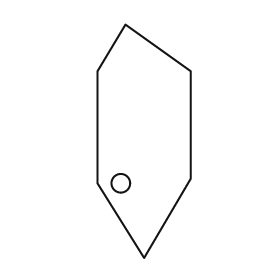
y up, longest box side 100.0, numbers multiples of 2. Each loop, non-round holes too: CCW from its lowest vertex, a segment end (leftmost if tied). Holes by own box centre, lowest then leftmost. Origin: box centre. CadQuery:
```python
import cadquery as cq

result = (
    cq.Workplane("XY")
    .moveTo(0.0, -50.0)
    .lineTo(20.0, -16.0)
    .lineTo(20.0, 30.0)
    .lineTo(-8.0, 50.0)
    .lineTo(-20.0, 30.0)
    .lineTo(-20.0, -18.0)
    .close()
    .moveTo(-10.0, -18.0)
    .circle(4.0)
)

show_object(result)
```